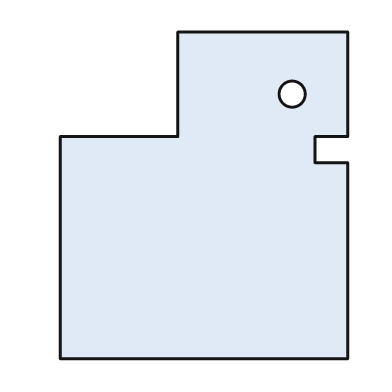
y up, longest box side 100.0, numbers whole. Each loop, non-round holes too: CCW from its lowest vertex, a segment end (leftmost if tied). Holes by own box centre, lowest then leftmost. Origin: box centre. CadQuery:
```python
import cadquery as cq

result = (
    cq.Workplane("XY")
    .moveTo(-44.0, -50.0)
    .lineTo(44.0, -50.0)
    .lineTo(44.0, 10.0)
    .lineTo(34.0, 10.0)
    .lineTo(34.0, 18.0)
    .lineTo(44.0, 18.0)
    .lineTo(44.0, 50.0)
    .lineTo(-8.0, 50.0)
    .lineTo(-8.0, 18.0)
    .lineTo(-44.0, 18.0)
    .close()
    .moveTo(27.0, 31.0)
    .circle(4.0)
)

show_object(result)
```